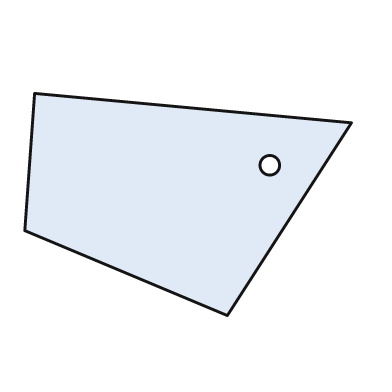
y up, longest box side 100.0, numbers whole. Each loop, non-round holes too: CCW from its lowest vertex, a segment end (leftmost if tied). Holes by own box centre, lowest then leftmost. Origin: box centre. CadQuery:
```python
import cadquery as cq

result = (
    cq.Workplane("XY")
    .moveTo(12.0, -34.0)
    .lineTo(50.0, 25.0)
    .lineTo(-47.0, 34.0)
    .lineTo(-50.0, -8.0)
    .close()
    .moveTo(25.0, 12.0)
    .circle(3.0)
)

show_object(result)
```